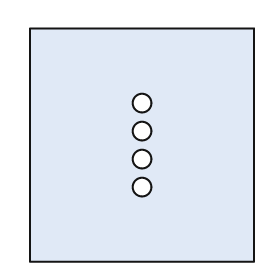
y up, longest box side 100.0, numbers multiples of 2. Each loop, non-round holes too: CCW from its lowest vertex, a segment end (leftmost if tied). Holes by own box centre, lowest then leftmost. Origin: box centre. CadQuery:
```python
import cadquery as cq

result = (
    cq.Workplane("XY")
    .moveTo(-48.0, -50.0)
    .lineTo(48.0, -50.0)
    .lineTo(48.0, 50.0)
    .lineTo(-48.0, 50.0)
    .close()
    .moveTo(0.0, -18.0)
    .circle(4.0)
    .moveTo(0.0, -6.0)
    .circle(4.0)
    .moveTo(0.0, 6.0)
    .circle(4.0)
    .moveTo(0.0, 18.0)
    .circle(4.0)
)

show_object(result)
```